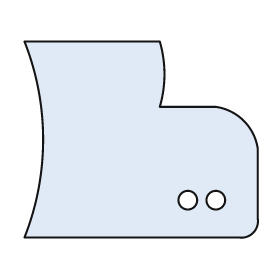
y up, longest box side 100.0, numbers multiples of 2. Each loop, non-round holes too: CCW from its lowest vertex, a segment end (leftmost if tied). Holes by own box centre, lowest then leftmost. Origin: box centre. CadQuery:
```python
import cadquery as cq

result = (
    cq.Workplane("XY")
    .moveTo(-50.0, -42.0)
    .lineTo(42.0, -42.0)
    .threePointArc((48.0, -40.0), (50.0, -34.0))
    .lineTo(50.0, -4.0)
    .threePointArc((44.0, 8.0), (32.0, 14.0))
    .lineTo(8.0, 14.0)
    .threePointArc((10.0, 28.0), (8.0, 42.0))
    .lineTo(-50.0, 42.0)
    .threePointArc((-42.0, 0.0), (-50.0, -42.0))
    .close()
    .moveTo(20.0, -26.0)
    .circle(4.0)
    .moveTo(32.0, -26.0)
    .circle(4.0)
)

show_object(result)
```